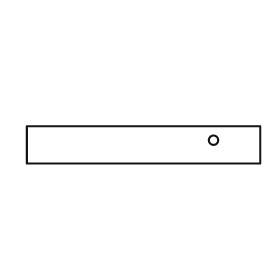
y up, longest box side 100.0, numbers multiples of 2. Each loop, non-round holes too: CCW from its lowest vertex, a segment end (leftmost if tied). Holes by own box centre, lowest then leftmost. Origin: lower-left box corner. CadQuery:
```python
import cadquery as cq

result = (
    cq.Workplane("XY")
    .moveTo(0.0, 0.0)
    .lineTo(100.0, 0.0)
    .lineTo(100.0, 16.0)
    .lineTo(0.0, 16.0)
    .close()
    .moveTo(80.0, 10.0)
    .circle(2.0)
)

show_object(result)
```